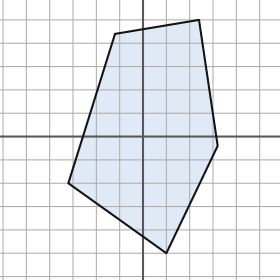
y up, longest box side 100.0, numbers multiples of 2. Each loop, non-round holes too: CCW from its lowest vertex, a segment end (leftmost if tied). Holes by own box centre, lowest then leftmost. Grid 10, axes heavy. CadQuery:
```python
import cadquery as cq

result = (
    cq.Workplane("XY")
    .moveTo(10.0, -50.0)
    .lineTo(32.0, -4.0)
    .lineTo(24.0, 50.0)
    .lineTo(-12.0, 44.0)
    .lineTo(-32.0, -20.0)
    .close()
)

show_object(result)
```